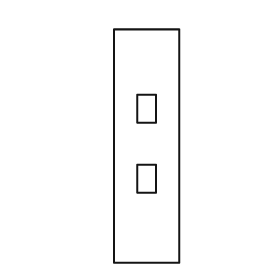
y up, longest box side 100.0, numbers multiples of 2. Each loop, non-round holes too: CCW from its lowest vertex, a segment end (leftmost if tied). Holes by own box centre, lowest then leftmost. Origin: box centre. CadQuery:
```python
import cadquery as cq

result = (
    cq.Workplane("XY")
    .moveTo(-14.0, -50.0)
    .lineTo(14.0, -50.0)
    .lineTo(14.0, 50.0)
    .lineTo(-14.0, 50.0)
    .close()
    .moveTo(-4.0, -20.0)
    .lineTo(4.0, -20.0)
    .lineTo(4.0, -8.0)
    .lineTo(-4.0, -8.0)
    .close()
    .moveTo(-4.0, 10.0)
    .lineTo(4.0, 10.0)
    .lineTo(4.0, 22.0)
    .lineTo(-4.0, 22.0)
    .close()
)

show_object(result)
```